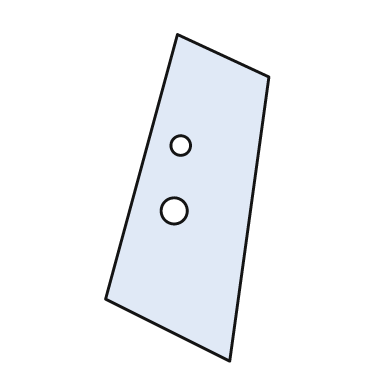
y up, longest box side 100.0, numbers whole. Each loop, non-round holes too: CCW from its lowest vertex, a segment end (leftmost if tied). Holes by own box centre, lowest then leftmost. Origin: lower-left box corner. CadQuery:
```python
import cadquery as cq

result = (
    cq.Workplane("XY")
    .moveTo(38.0, 0.0)
    .lineTo(50.0, 87.0)
    .lineTo(22.0, 100.0)
    .lineTo(0.0, 19.0)
    .close()
    .moveTo(21.0, 46.0)
    .circle(4.0)
    .moveTo(23.0, 66.0)
    .circle(3.0)
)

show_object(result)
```